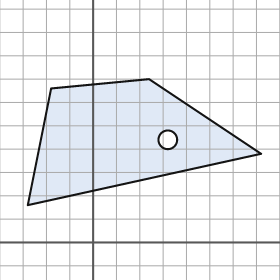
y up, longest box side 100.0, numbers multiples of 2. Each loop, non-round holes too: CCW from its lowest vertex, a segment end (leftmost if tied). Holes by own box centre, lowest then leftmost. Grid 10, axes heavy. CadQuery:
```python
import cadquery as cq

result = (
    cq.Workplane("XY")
    .moveTo(-28.0, 16.0)
    .lineTo(72.0, 38.0)
    .lineTo(24.0, 70.0)
    .lineTo(-18.0, 66.0)
    .close()
    .moveTo(32.0, 44.0)
    .circle(4.0)
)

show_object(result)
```